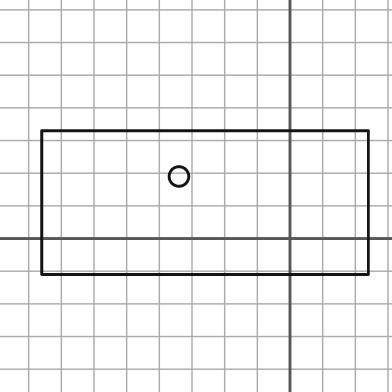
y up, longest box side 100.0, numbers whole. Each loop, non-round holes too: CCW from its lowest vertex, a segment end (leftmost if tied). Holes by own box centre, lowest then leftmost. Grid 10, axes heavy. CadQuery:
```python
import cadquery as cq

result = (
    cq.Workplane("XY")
    .moveTo(-76.0, -11.0)
    .lineTo(24.0, -11.0)
    .lineTo(24.0, 33.0)
    .lineTo(-76.0, 33.0)
    .close()
    .moveTo(-34.0, 19.0)
    .circle(3.0)
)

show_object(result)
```